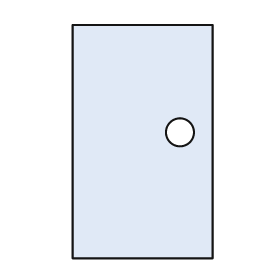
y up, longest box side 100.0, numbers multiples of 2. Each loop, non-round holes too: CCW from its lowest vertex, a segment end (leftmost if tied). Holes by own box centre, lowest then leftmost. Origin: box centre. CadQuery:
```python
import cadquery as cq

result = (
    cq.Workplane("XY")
    .moveTo(-30.0, -50.0)
    .lineTo(30.0, -50.0)
    .lineTo(30.0, 50.0)
    .lineTo(-30.0, 50.0)
    .close()
    .moveTo(16.0, 4.0)
    .circle(6.0)
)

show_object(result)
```